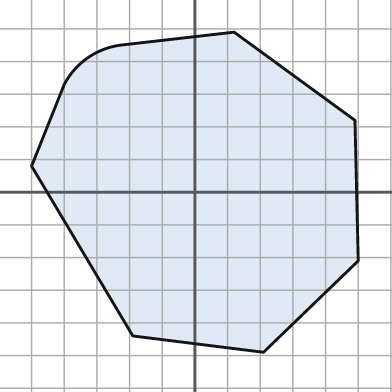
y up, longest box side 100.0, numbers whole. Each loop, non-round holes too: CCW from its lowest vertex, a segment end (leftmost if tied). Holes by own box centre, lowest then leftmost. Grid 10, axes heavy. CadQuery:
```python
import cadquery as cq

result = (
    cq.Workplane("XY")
    .moveTo(21.0, -49.0)
    .lineTo(50.0, -21.0)
    .lineTo(49.0, 22.0)
    .lineTo(12.0, 49.0)
    .lineTo(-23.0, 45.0)
    .threePointArc((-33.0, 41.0), (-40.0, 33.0))
    .lineTo(-50.0, 8.0)
    .lineTo(-19.0, -44.0)
    .close()
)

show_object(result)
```